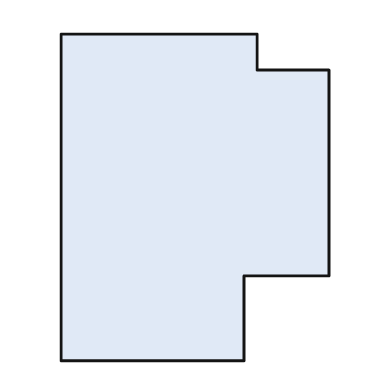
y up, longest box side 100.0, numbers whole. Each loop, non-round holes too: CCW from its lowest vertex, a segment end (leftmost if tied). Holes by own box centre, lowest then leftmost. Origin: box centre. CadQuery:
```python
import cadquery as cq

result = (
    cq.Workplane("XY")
    .moveTo(-41.0, -50.0)
    .lineTo(15.0, -50.0)
    .lineTo(15.0, -24.0)
    .lineTo(41.0, -24.0)
    .lineTo(41.0, 39.0)
    .lineTo(19.0, 39.0)
    .lineTo(19.0, 50.0)
    .lineTo(-41.0, 50.0)
    .close()
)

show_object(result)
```